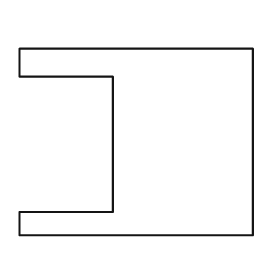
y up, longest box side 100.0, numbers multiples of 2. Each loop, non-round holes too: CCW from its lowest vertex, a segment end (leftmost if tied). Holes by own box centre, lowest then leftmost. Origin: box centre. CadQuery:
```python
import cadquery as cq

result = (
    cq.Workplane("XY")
    .moveTo(-50.0, -40.0)
    .lineTo(50.0, -40.0)
    .lineTo(50.0, 40.0)
    .lineTo(-50.0, 40.0)
    .lineTo(-50.0, 28.0)
    .lineTo(-10.0, 28.0)
    .lineTo(-10.0, -30.0)
    .lineTo(-50.0, -30.0)
    .close()
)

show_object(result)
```